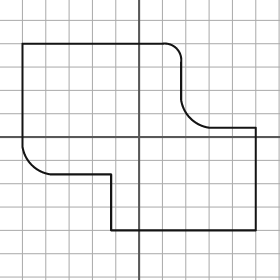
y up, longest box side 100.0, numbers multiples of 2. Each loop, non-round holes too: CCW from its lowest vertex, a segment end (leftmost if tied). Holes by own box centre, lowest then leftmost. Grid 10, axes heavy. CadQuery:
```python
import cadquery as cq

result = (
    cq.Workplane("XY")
    .moveTo(-12.0, -40.0)
    .lineTo(50.0, -40.0)
    .lineTo(50.0, 4.0)
    .lineTo(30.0, 4.0)
    .threePointArc((22.0, 8.0), (18.0, 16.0))
    .lineTo(18.0, 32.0)
    .threePointArc((16.0, 38.0), (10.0, 40.0))
    .lineTo(-50.0, 40.0)
    .lineTo(-50.0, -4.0)
    .threePointArc((-46.0, -12.0), (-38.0, -16.0))
    .lineTo(-12.0, -16.0)
    .close()
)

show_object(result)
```